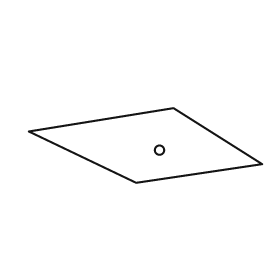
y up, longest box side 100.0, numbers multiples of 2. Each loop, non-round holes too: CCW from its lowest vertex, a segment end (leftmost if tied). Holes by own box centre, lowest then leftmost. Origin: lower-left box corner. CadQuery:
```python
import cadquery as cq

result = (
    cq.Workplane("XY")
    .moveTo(46.0, 0.0)
    .lineTo(100.0, 8.0)
    .lineTo(62.0, 32.0)
    .lineTo(0.0, 22.0)
    .close()
    .moveTo(56.0, 14.0)
    .circle(2.0)
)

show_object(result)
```